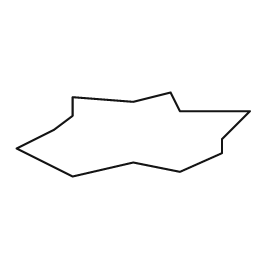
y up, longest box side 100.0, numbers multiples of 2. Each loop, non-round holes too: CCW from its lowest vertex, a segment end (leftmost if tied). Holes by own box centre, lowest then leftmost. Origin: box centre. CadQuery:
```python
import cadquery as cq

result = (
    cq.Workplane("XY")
    .moveTo(-26.0, -18.0)
    .lineTo(0.0, -12.0)
    .lineTo(20.0, -16.0)
    .lineTo(38.0, -8.0)
    .lineTo(38.0, -2.0)
    .lineTo(50.0, 10.0)
    .lineTo(20.0, 10.0)
    .lineTo(16.0, 18.0)
    .lineTo(0.0, 14.0)
    .lineTo(-26.0, 16.0)
    .lineTo(-26.0, 8.0)
    .lineTo(-34.0, 2.0)
    .lineTo(-50.0, -6.0)
    .close()
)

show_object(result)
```